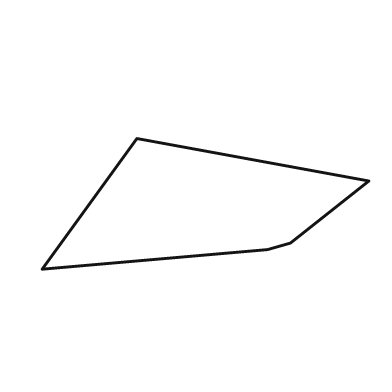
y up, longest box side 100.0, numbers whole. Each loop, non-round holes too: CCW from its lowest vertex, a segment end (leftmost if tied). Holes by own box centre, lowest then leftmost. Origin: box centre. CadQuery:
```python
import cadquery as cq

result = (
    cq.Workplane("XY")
    .moveTo(-50.0, -20.0)
    .lineTo(19.0, -14.0)
    .lineTo(26.0, -12.0)
    .lineTo(50.0, 7.0)
    .lineTo(-21.0, 20.0)
    .close()
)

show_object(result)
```